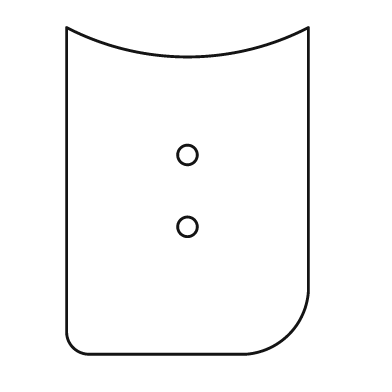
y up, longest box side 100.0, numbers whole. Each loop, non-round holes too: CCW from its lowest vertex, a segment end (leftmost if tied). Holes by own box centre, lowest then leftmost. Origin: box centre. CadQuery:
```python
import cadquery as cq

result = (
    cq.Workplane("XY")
    .moveTo(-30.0, -50.0)
    .lineTo(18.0, -50.0)
    .threePointArc((31.0, -44.0), (37.0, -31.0))
    .lineTo(37.0, 50.0)
    .threePointArc((0.0, 41.0), (-37.0, 50.0))
    .lineTo(-37.0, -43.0)
    .threePointArc((-35.0, -48.0), (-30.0, -50.0))
    .close()
    .moveTo(0.0, -11.0)
    .circle(3.0)
    .moveTo(0.0, 11.0)
    .circle(3.0)
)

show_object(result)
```